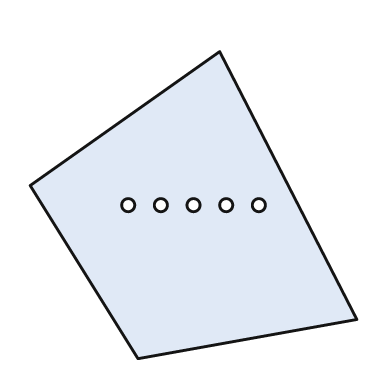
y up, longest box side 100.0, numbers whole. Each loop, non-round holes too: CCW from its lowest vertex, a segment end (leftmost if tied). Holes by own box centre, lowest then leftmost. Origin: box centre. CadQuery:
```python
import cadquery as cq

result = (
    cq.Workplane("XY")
    .moveTo(-17.0, -47.0)
    .lineTo(50.0, -35.0)
    .lineTo(8.0, 47.0)
    .lineTo(-50.0, 6.0)
    .close()
    .moveTo(-20.0, 0.0)
    .circle(2.0)
    .moveTo(-10.0, 0.0)
    .circle(2.0)
    .moveTo(0.0, 0.0)
    .circle(2.0)
    .moveTo(10.0, 0.0)
    .circle(2.0)
    .moveTo(20.0, 0.0)
    .circle(2.0)
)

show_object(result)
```